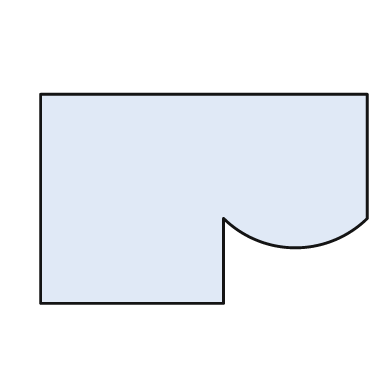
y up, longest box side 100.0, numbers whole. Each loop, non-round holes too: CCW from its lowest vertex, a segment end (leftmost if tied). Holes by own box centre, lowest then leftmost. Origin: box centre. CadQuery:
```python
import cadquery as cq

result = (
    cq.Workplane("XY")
    .moveTo(-50.0, -32.0)
    .lineTo(6.0, -32.0)
    .lineTo(6.0, -6.0)
    .threePointArc((28.0, -15.0), (50.0, -6.0))
    .lineTo(50.0, 32.0)
    .lineTo(-50.0, 32.0)
    .close()
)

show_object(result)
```